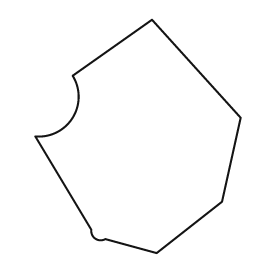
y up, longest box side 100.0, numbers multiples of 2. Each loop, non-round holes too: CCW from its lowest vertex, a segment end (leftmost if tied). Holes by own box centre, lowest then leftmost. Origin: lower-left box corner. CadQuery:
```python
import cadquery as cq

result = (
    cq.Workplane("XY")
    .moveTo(52.0, 0.0)
    .lineTo(80.0, 22.0)
    .lineTo(88.0, 58.0)
    .lineTo(50.0, 100.0)
    .lineTo(16.0, 76.0)
    .threePointArc((16.0, 58.0), (0.0, 50.0))
    .lineTo(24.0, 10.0)
    .threePointArc((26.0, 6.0), (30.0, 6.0))
    .close()
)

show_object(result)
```